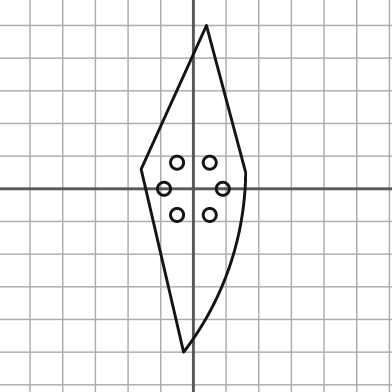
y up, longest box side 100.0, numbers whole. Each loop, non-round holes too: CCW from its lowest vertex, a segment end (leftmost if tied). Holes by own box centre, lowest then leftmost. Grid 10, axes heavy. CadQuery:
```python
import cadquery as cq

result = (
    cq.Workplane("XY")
    .moveTo(-3.0, -50.0)
    .threePointArc((11.0, -24.0), (16.0, 5.0))
    .lineTo(4.0, 50.0)
    .lineTo(-16.0, 6.0)
    .close()
    .moveTo(-5.0, -8.0)
    .circle(2.0)
    .moveTo(5.0, -8.0)
    .circle(2.0)
    .moveTo(-9.0, 0.0)
    .circle(2.0)
    .moveTo(9.0, 0.0)
    .circle(2.0)
    .moveTo(-5.0, 8.0)
    .circle(2.0)
    .moveTo(5.0, 8.0)
    .circle(2.0)
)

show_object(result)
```